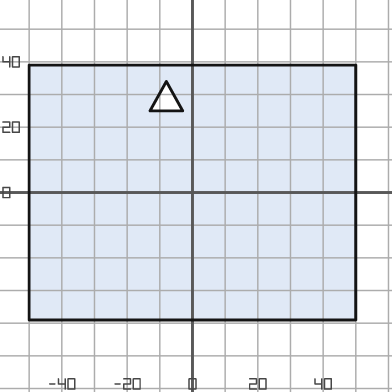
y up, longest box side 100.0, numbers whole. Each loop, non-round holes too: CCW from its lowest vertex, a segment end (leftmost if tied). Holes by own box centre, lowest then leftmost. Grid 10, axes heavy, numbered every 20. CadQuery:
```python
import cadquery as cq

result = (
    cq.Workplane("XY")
    .moveTo(-50.0, -39.0)
    .lineTo(50.0, -39.0)
    .lineTo(50.0, 39.0)
    .lineTo(-50.0, 39.0)
    .close()
    .moveTo(-13.0, 25.0)
    .lineTo(-3.0, 25.0)
    .lineTo(-8.0, 34.0)
    .close()
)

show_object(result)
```